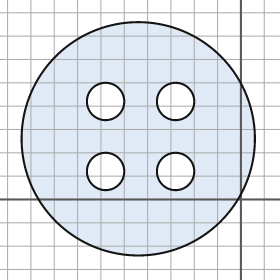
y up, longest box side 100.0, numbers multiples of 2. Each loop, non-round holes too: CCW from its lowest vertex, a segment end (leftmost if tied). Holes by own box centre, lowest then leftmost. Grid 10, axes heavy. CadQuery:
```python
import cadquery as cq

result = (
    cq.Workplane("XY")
    .moveTo(-44.0, 26.0)
    .circle(50.0)
    .moveTo(-58.0, 12.0)
    .circle(8.0)
    .moveTo(-28.0, 12.0)
    .circle(8.0)
    .moveTo(-58.0, 42.0)
    .circle(8.0)
    .moveTo(-28.0, 42.0)
    .circle(8.0)
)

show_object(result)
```